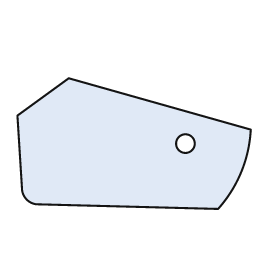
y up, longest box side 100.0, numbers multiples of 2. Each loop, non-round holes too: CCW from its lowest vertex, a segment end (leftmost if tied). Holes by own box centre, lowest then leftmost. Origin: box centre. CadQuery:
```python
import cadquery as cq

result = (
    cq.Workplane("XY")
    .moveTo(36.0, -28.0)
    .threePointArc((46.0, -12.0), (50.0, 6.0))
    .lineTo(-28.0, 28.0)
    .lineTo(-50.0, 12.0)
    .lineTo(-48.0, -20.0)
    .threePointArc((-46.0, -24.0), (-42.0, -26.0))
    .close()
    .moveTo(22.0, 0.0)
    .circle(4.0)
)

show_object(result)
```